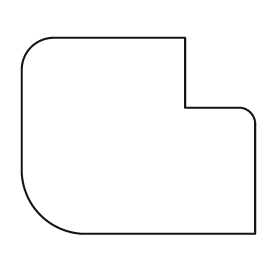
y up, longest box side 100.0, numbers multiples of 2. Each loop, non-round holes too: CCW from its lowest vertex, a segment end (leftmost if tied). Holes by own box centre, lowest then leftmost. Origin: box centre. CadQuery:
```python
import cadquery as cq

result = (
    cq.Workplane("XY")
    .moveTo(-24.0, -42.0)
    .lineTo(50.0, -42.0)
    .lineTo(50.0, 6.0)
    .threePointArc((48.0, 10.0), (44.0, 12.0))
    .lineTo(20.0, 12.0)
    .lineTo(20.0, 42.0)
    .lineTo(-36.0, 42.0)
    .threePointArc((-46.0, 38.0), (-50.0, 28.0))
    .lineTo(-50.0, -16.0)
    .threePointArc((-42.0, -34.0), (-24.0, -42.0))
    .close()
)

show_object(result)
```